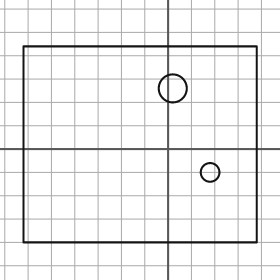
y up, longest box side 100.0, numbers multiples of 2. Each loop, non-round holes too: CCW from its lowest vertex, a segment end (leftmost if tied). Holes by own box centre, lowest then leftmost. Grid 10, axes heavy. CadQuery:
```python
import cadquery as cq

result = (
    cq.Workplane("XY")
    .moveTo(-62.0, -40.0)
    .lineTo(38.0, -40.0)
    .lineTo(38.0, 44.0)
    .lineTo(-62.0, 44.0)
    .close()
    .moveTo(18.0, -10.0)
    .circle(4.0)
    .moveTo(2.0, 26.0)
    .circle(6.0)
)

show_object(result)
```